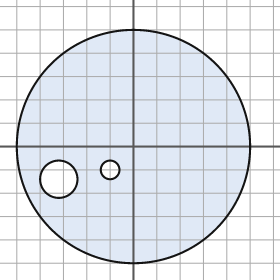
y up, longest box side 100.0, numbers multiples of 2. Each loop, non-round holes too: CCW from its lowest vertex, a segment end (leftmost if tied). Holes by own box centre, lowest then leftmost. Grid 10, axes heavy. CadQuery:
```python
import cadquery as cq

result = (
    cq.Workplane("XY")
    .moveTo(0.0, 0.0)
    .circle(50.0)
    .moveTo(-32.0, -14.0)
    .circle(8.0)
    .moveTo(-10.0, -10.0)
    .circle(4.0)
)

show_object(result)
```